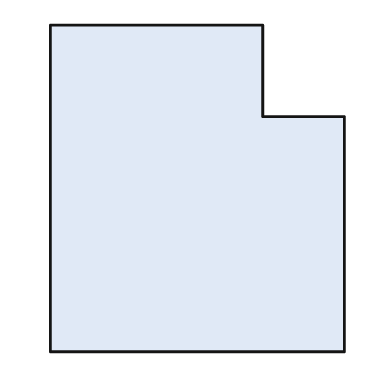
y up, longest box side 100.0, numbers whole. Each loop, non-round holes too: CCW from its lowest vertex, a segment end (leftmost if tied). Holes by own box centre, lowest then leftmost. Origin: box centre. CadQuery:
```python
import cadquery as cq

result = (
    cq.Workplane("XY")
    .moveTo(-45.0, -50.0)
    .lineTo(45.0, -50.0)
    .lineTo(45.0, 22.0)
    .lineTo(20.0, 22.0)
    .lineTo(20.0, 50.0)
    .lineTo(-45.0, 50.0)
    .close()
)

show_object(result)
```